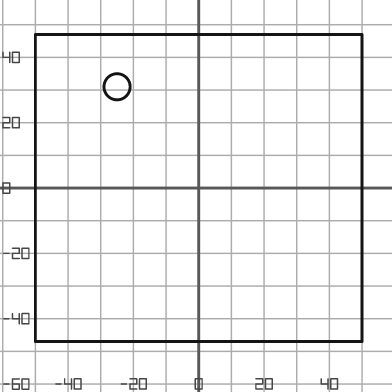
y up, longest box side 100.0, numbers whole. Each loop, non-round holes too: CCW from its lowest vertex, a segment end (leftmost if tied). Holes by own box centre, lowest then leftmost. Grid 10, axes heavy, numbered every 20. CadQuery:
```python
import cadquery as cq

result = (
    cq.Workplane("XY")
    .moveTo(-50.0, -47.0)
    .lineTo(50.0, -47.0)
    .lineTo(50.0, 47.0)
    .lineTo(-50.0, 47.0)
    .close()
    .moveTo(-25.0, 31.0)
    .circle(4.0)
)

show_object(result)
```